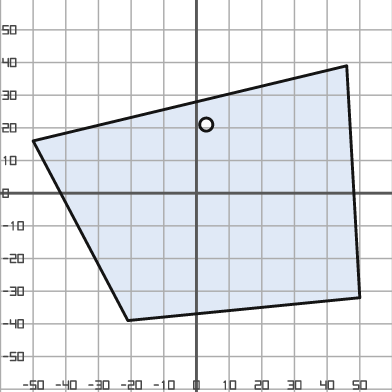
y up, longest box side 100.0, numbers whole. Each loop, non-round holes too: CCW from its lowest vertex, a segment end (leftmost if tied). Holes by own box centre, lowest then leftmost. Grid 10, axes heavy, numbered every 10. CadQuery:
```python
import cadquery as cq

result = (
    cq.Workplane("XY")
    .moveTo(-21.0, -39.0)
    .lineTo(50.0, -32.0)
    .lineTo(46.0, 39.0)
    .lineTo(-50.0, 16.0)
    .close()
    .moveTo(3.0, 21.0)
    .circle(2.0)
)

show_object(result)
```